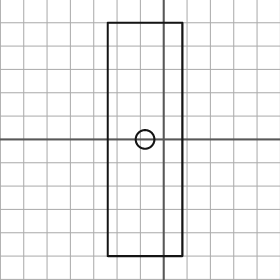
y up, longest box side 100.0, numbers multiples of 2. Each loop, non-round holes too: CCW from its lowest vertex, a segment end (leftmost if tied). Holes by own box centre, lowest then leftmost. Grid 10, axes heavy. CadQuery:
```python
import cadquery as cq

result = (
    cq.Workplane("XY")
    .moveTo(-24.0, -50.0)
    .lineTo(8.0, -50.0)
    .lineTo(8.0, 50.0)
    .lineTo(-24.0, 50.0)
    .close()
    .moveTo(-8.0, 0.0)
    .circle(4.0)
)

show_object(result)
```